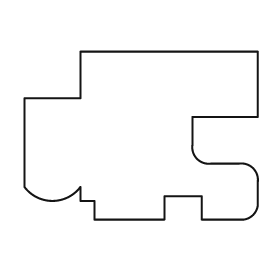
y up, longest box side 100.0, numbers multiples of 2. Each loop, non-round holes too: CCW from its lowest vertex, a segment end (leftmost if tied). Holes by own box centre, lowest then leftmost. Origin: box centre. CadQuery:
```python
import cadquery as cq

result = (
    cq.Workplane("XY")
    .moveTo(-20.0, -36.0)
    .lineTo(10.0, -36.0)
    .lineTo(10.0, -26.0)
    .lineTo(26.0, -26.0)
    .lineTo(26.0, -36.0)
    .lineTo(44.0, -36.0)
    .threePointArc((48.0, -34.0), (50.0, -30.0))
    .lineTo(50.0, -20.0)
    .threePointArc((48.0, -14.0), (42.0, -12.0))
    .lineTo(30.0, -12.0)
    .threePointArc((24.0, -10.0), (22.0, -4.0))
    .lineTo(22.0, 8.0)
    .lineTo(50.0, 8.0)
    .lineTo(50.0, 36.0)
    .lineTo(-26.0, 36.0)
    .lineTo(-26.0, 16.0)
    .lineTo(-50.0, 16.0)
    .lineTo(-50.0, -22.0)
    .threePointArc((-38.0, -28.0), (-26.0, -22.0))
    .lineTo(-26.0, -28.0)
    .lineTo(-20.0, -28.0)
    .close()
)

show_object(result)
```